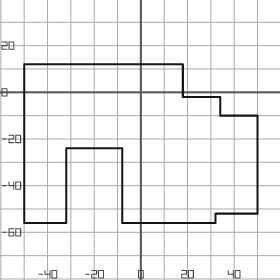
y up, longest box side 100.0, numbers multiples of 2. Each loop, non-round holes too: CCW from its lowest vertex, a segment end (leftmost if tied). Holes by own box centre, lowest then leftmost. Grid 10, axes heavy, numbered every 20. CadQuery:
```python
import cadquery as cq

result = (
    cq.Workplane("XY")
    .moveTo(-50.0, -56.0)
    .lineTo(-32.0, -56.0)
    .lineTo(-32.0, -24.0)
    .lineTo(-8.0, -24.0)
    .lineTo(-8.0, -56.0)
    .lineTo(32.0, -56.0)
    .lineTo(32.0, -52.0)
    .lineTo(50.0, -52.0)
    .lineTo(50.0, -10.0)
    .lineTo(34.0, -10.0)
    .lineTo(34.0, -2.0)
    .lineTo(18.0, -2.0)
    .lineTo(18.0, 12.0)
    .lineTo(-50.0, 12.0)
    .close()
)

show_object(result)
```